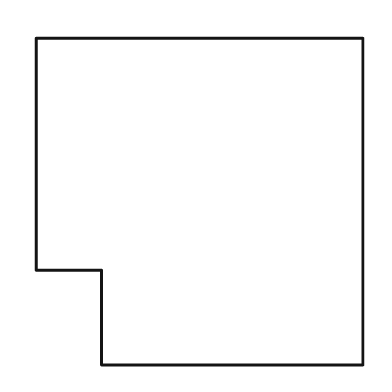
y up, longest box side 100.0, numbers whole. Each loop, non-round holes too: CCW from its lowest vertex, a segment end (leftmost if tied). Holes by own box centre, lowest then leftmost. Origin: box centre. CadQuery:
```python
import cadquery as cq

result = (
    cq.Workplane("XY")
    .moveTo(-30.0, -50.0)
    .lineTo(50.0, -50.0)
    .lineTo(50.0, 50.0)
    .lineTo(-50.0, 50.0)
    .lineTo(-50.0, -21.0)
    .lineTo(-30.0, -21.0)
    .close()
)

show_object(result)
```